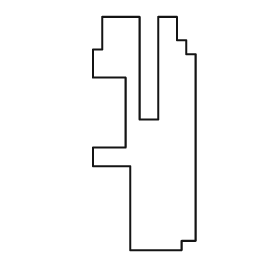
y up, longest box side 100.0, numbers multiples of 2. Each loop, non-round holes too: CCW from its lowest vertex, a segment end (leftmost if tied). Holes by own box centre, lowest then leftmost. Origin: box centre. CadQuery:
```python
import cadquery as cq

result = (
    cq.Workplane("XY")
    .moveTo(-6.0, -50.0)
    .lineTo(16.0, -50.0)
    .lineTo(16.0, -46.0)
    .lineTo(22.0, -46.0)
    .lineTo(22.0, 34.0)
    .lineTo(18.0, 34.0)
    .lineTo(18.0, 40.0)
    .lineTo(14.0, 40.0)
    .lineTo(14.0, 50.0)
    .lineTo(6.0, 50.0)
    .lineTo(6.0, 6.0)
    .lineTo(-2.0, 6.0)
    .lineTo(-2.0, 50.0)
    .lineTo(-18.0, 50.0)
    .lineTo(-18.0, 36.0)
    .lineTo(-22.0, 36.0)
    .lineTo(-22.0, 24.0)
    .lineTo(-8.0, 24.0)
    .lineTo(-8.0, -6.0)
    .lineTo(-22.0, -6.0)
    .lineTo(-22.0, -14.0)
    .lineTo(-6.0, -14.0)
    .close()
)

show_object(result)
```